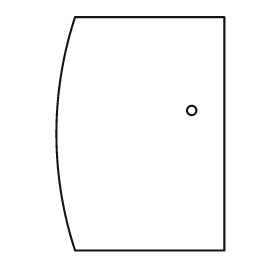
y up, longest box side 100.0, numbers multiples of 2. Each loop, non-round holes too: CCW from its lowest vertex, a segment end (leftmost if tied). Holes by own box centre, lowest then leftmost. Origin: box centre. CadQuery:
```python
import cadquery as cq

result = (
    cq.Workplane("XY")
    .moveTo(-28.0, -50.0)
    .lineTo(36.0, -50.0)
    .lineTo(36.0, 50.0)
    .lineTo(-28.0, 50.0)
    .threePointArc((-36.0, 0.0), (-28.0, -50.0))
    .close()
    .moveTo(22.0, 10.0)
    .circle(2.0)
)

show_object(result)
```